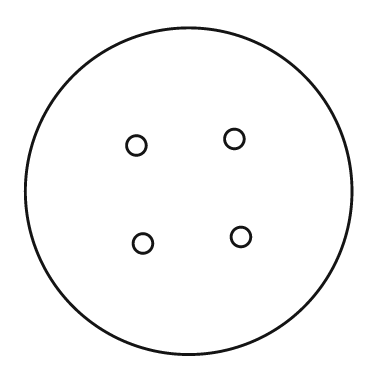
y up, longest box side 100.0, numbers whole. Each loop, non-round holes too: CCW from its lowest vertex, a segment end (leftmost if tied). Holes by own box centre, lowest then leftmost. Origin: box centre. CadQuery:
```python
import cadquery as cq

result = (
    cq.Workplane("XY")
    .moveTo(0.0, 0.0)
    .circle(50.0)
    .moveTo(-14.0, -16.0)
    .circle(3.0)
    .moveTo(16.0, -14.0)
    .circle(3.0)
    .moveTo(-16.0, 14.0)
    .circle(3.0)
    .moveTo(14.0, 16.0)
    .circle(3.0)
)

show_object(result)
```